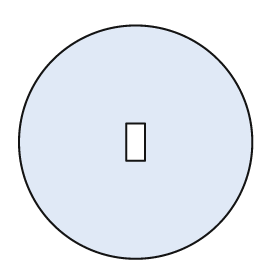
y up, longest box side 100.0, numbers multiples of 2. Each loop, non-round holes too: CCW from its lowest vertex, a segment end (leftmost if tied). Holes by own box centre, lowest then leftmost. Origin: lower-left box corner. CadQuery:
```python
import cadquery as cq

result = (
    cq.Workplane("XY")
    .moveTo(50.0, 50.0)
    .circle(50.0)
    .moveTo(46.0, 42.0)
    .lineTo(54.0, 42.0)
    .lineTo(54.0, 58.0)
    .lineTo(46.0, 58.0)
    .close()
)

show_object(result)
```